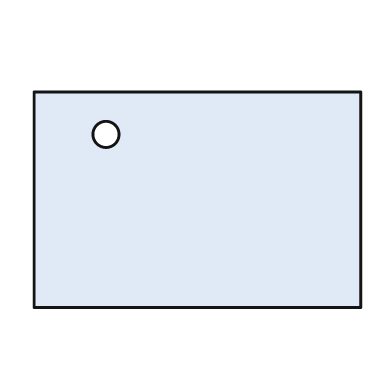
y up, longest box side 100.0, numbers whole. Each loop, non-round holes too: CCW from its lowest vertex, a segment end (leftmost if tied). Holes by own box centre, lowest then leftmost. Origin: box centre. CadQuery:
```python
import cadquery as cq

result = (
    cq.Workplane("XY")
    .moveTo(-50.0, -33.0)
    .lineTo(50.0, -33.0)
    .lineTo(50.0, 33.0)
    .lineTo(-50.0, 33.0)
    .close()
    .moveTo(-28.0, 20.0)
    .circle(4.0)
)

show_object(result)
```